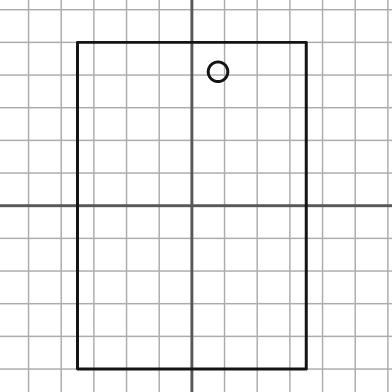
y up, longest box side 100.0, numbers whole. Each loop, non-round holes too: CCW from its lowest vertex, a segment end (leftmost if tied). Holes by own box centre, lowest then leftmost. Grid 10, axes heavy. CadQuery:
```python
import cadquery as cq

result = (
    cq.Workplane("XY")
    .moveTo(-35.0, -50.0)
    .lineTo(35.0, -50.0)
    .lineTo(35.0, 50.0)
    .lineTo(-35.0, 50.0)
    .close()
    .moveTo(8.0, 41.0)
    .circle(3.0)
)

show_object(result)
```